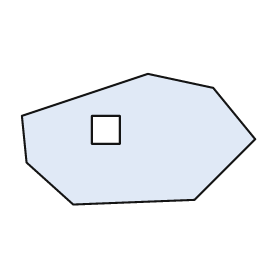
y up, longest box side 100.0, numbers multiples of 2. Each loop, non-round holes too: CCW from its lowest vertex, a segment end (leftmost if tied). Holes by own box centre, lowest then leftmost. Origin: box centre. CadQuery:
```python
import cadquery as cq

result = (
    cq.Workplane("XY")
    .moveTo(-28.0, -28.0)
    .lineTo(24.0, -26.0)
    .lineTo(50.0, 0.0)
    .lineTo(32.0, 22.0)
    .lineTo(4.0, 28.0)
    .lineTo(-50.0, 10.0)
    .lineTo(-48.0, -10.0)
    .close()
    .moveTo(-20.0, -2.0)
    .lineTo(-8.0, -2.0)
    .lineTo(-8.0, 10.0)
    .lineTo(-20.0, 10.0)
    .close()
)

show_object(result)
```